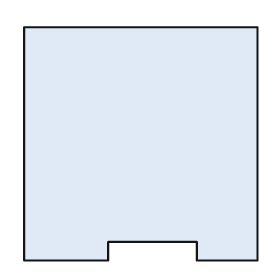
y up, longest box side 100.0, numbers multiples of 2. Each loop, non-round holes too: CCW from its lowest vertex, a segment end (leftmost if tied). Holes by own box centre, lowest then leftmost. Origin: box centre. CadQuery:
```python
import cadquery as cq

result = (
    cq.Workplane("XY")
    .moveTo(-50.0, -50.0)
    .lineTo(-14.0, -50.0)
    .lineTo(-14.0, -42.0)
    .lineTo(24.0, -42.0)
    .lineTo(24.0, -50.0)
    .lineTo(50.0, -50.0)
    .lineTo(50.0, 50.0)
    .lineTo(-50.0, 50.0)
    .close()
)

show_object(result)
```